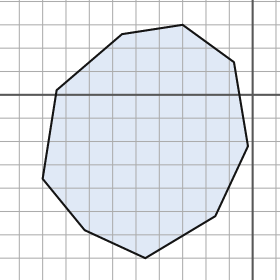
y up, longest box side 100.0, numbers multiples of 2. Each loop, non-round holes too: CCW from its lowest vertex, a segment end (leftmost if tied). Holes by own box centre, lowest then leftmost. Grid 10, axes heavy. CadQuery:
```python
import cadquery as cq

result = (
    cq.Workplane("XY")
    .moveTo(-46.0, -70.0)
    .lineTo(-16.0, -52.0)
    .lineTo(-2.0, -22.0)
    .lineTo(-8.0, 14.0)
    .lineTo(-30.0, 30.0)
    .lineTo(-56.0, 26.0)
    .lineTo(-84.0, 2.0)
    .lineTo(-90.0, -36.0)
    .lineTo(-72.0, -58.0)
    .close()
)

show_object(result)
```